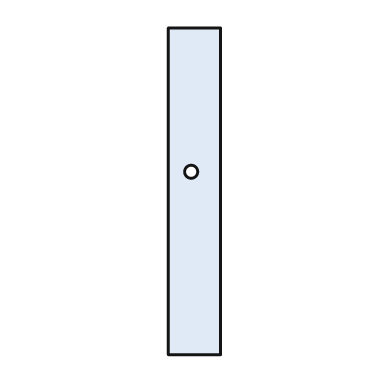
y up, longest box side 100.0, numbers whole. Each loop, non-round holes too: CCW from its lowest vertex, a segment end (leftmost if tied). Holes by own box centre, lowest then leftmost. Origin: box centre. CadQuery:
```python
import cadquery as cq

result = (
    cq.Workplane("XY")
    .moveTo(-8.0, -50.0)
    .lineTo(8.0, -50.0)
    .lineTo(8.0, 50.0)
    .lineTo(-8.0, 50.0)
    .close()
    .moveTo(-1.0, 6.0)
    .circle(2.0)
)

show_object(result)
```